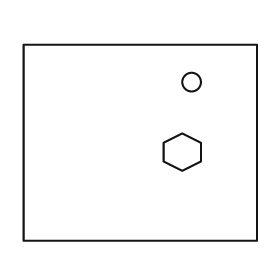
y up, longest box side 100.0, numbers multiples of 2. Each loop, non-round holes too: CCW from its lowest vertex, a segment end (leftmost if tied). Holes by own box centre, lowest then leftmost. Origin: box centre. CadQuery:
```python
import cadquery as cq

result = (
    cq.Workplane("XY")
    .moveTo(-50.0, -42.0)
    .lineTo(50.0, -42.0)
    .lineTo(50.0, 42.0)
    .lineTo(-50.0, 42.0)
    .close()
    .moveTo(18.0, -12.0)
    .lineTo(26.0, -8.0)
    .lineTo(26.0, 0.0)
    .lineTo(18.0, 4.0)
    .lineTo(10.0, 0.0)
    .lineTo(10.0, -8.0)
    .close()
    .moveTo(22.0, 26.0)
    .circle(4.0)
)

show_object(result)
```